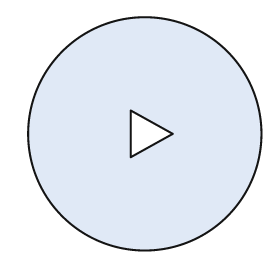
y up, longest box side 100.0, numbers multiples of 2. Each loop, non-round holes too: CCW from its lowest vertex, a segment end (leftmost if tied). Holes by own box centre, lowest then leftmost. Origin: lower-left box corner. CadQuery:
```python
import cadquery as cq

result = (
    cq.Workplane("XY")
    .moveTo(50.0, 50.0)
    .circle(50.0)
    .moveTo(44.0, 40.0)
    .lineTo(62.0, 50.0)
    .lineTo(44.0, 60.0)
    .close()
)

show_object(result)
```